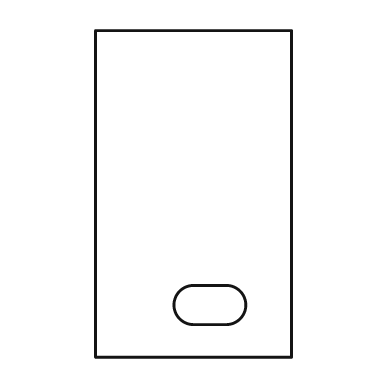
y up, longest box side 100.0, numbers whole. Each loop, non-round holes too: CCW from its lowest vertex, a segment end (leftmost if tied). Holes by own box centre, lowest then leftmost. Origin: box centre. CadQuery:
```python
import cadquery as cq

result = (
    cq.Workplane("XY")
    .moveTo(-30.0, -50.0)
    .lineTo(30.0, -50.0)
    .lineTo(30.0, 50.0)
    .lineTo(-30.0, 50.0)
    .close()
    .moveTo(0.0, -40.0)
    .lineTo(10.0, -40.0)
    .threePointArc((16.0, -34.0), (10.0, -28.0))
    .lineTo(0.0, -28.0)
    .threePointArc((-6.0, -34.0), (0.0, -40.0))
    .close()
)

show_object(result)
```